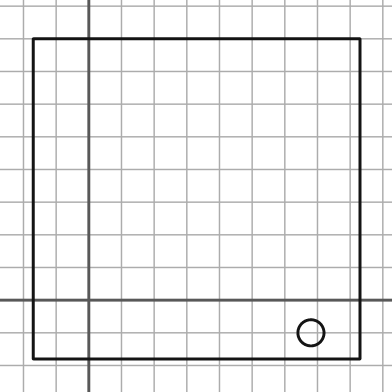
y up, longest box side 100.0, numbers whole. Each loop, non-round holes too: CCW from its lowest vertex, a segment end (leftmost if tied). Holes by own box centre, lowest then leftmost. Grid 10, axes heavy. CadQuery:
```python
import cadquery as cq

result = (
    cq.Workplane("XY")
    .moveTo(-17.0, -18.0)
    .lineTo(83.0, -18.0)
    .lineTo(83.0, 80.0)
    .lineTo(-17.0, 80.0)
    .close()
    .moveTo(68.0, -10.0)
    .circle(4.0)
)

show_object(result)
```